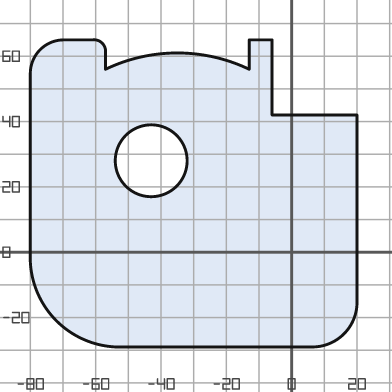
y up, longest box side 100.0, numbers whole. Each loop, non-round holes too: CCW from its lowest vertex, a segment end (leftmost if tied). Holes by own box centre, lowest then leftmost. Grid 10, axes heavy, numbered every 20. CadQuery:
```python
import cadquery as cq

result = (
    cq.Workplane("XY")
    .moveTo(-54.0, -29.0)
    .lineTo(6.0, -29.0)
    .threePointArc((16.0, -25.0), (20.0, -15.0))
    .lineTo(20.0, 42.0)
    .lineTo(-6.0, 42.0)
    .lineTo(-6.0, 65.0)
    .lineTo(-13.0, 65.0)
    .lineTo(-13.0, 56.0)
    .threePointArc((-35.0, 61.0), (-57.0, 56.0))
    .lineTo(-57.0, 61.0)
    .threePointArc((-58.0, 64.0), (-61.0, 65.0))
    .lineTo(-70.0, 65.0)
    .threePointArc((-77.0, 62.0), (-80.0, 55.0))
    .lineTo(-80.0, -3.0)
    .threePointArc((-72.0, -21.0), (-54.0, -29.0))
    .close()
    .moveTo(-43.0, 28.0)
    .circle(11.0)
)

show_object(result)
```